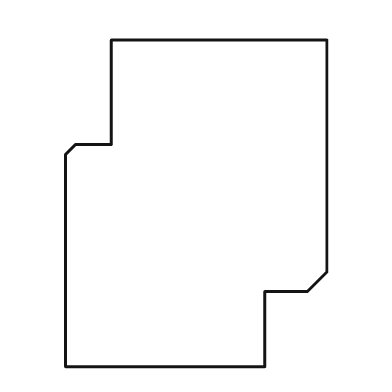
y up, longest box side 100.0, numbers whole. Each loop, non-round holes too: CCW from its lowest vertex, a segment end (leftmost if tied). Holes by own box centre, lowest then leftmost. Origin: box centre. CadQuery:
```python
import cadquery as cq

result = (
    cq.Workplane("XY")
    .moveTo(-40.0, -50.0)
    .lineTo(21.0, -50.0)
    .lineTo(21.0, -27.0)
    .lineTo(34.0, -27.0)
    .lineTo(40.0, -21.0)
    .lineTo(40.0, 50.0)
    .lineTo(-26.0, 50.0)
    .lineTo(-26.0, 18.0)
    .lineTo(-37.0, 18.0)
    .lineTo(-40.0, 15.0)
    .close()
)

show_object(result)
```